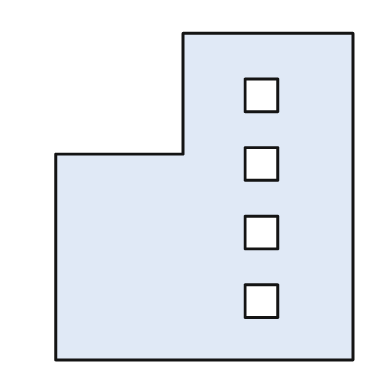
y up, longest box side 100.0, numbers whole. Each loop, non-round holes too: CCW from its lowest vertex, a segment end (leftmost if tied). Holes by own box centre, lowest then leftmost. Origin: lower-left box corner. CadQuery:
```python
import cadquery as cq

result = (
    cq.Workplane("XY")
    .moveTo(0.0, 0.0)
    .lineTo(91.0, 0.0)
    .lineTo(91.0, 100.0)
    .lineTo(39.0, 100.0)
    .lineTo(39.0, 63.0)
    .lineTo(0.0, 63.0)
    .close()
    .moveTo(58.0, 13.0)
    .lineTo(68.0, 13.0)
    .lineTo(68.0, 23.0)
    .lineTo(58.0, 23.0)
    .close()
    .moveTo(58.0, 34.0)
    .lineTo(68.0, 34.0)
    .lineTo(68.0, 44.0)
    .lineTo(58.0, 44.0)
    .close()
    .moveTo(58.0, 55.0)
    .lineTo(68.0, 55.0)
    .lineTo(68.0, 65.0)
    .lineTo(58.0, 65.0)
    .close()
    .moveTo(58.0, 76.0)
    .lineTo(68.0, 76.0)
    .lineTo(68.0, 86.0)
    .lineTo(58.0, 86.0)
    .close()
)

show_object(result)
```